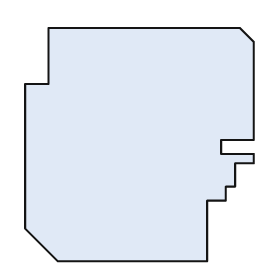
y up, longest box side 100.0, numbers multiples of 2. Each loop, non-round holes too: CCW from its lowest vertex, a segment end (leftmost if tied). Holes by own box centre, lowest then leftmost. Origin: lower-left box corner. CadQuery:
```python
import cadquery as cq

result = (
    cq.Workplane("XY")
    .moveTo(14.0, 0.0)
    .lineTo(78.0, 0.0)
    .lineTo(78.0, 26.0)
    .lineTo(86.0, 26.0)
    .lineTo(86.0, 32.0)
    .lineTo(90.0, 32.0)
    .lineTo(90.0, 42.0)
    .lineTo(98.0, 42.0)
    .lineTo(98.0, 46.0)
    .lineTo(84.0, 46.0)
    .lineTo(84.0, 52.0)
    .lineTo(98.0, 52.0)
    .lineTo(98.0, 94.0)
    .lineTo(92.0, 100.0)
    .lineTo(10.0, 100.0)
    .lineTo(10.0, 76.0)
    .lineTo(0.0, 76.0)
    .lineTo(0.0, 14.0)
    .close()
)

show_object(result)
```